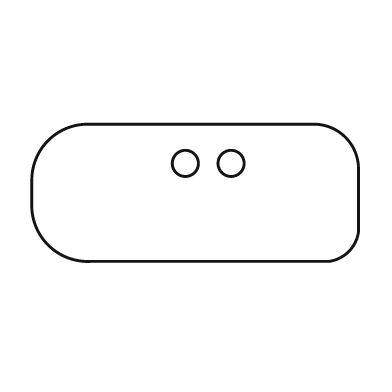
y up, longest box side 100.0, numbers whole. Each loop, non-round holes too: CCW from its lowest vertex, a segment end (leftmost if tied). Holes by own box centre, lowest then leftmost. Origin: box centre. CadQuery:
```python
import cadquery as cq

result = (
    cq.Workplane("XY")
    .moveTo(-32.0, -21.0)
    .lineTo(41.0, -21.0)
    .threePointArc((47.0, -18.0), (50.0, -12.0))
    .lineTo(50.0, 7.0)
    .threePointArc((46.0, 17.0), (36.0, 21.0))
    .lineTo(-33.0, 21.0)
    .threePointArc((-45.0, 16.0), (-50.0, 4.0))
    .lineTo(-50.0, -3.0)
    .threePointArc((-45.0, -16.0), (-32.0, -21.0))
    .close()
    .moveTo(-3.0, 9.0)
    .circle(4.0)
    .moveTo(11.0, 9.0)
    .circle(4.0)
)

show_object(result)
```